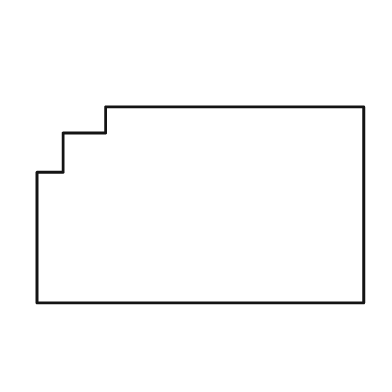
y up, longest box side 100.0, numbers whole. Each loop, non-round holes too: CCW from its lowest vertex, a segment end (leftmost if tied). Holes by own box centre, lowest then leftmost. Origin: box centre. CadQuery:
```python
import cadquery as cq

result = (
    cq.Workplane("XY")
    .moveTo(-50.0, -30.0)
    .lineTo(50.0, -30.0)
    .lineTo(50.0, 30.0)
    .lineTo(-29.0, 30.0)
    .lineTo(-29.0, 22.0)
    .lineTo(-42.0, 22.0)
    .lineTo(-42.0, 10.0)
    .lineTo(-50.0, 10.0)
    .close()
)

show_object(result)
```